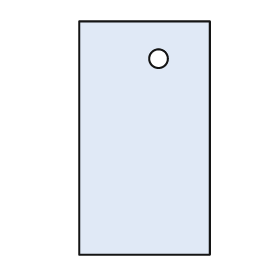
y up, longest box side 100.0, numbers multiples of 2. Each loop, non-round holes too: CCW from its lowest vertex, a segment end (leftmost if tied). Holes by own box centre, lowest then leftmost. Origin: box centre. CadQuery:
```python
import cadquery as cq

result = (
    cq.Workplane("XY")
    .moveTo(-28.0, -50.0)
    .lineTo(28.0, -50.0)
    .lineTo(28.0, 50.0)
    .lineTo(-28.0, 50.0)
    .close()
    .moveTo(6.0, 34.0)
    .circle(4.0)
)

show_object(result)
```